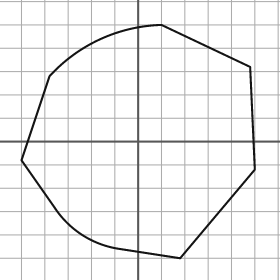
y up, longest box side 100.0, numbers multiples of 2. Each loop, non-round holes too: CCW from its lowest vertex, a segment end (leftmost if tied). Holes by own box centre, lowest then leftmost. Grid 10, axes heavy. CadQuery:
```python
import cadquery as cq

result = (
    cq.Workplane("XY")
    .moveTo(18.0, -50.0)
    .lineTo(50.0, -12.0)
    .lineTo(48.0, 32.0)
    .lineTo(10.0, 50.0)
    .threePointArc((-16.0, 44.0), (-38.0, 28.0))
    .lineTo(-50.0, -8.0)
    .lineTo(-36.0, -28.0)
    .threePointArc((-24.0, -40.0), (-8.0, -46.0))
    .close()
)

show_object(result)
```